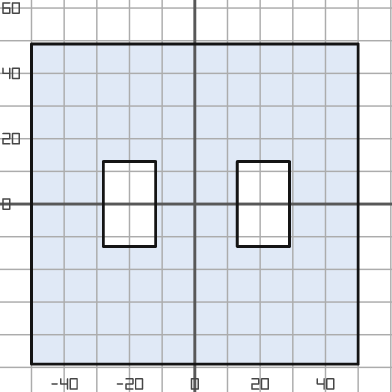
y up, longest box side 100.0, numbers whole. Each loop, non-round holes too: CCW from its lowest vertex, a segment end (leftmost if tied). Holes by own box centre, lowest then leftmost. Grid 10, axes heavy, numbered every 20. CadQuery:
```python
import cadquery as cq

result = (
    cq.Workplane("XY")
    .moveTo(-50.0, -49.0)
    .lineTo(50.0, -49.0)
    .lineTo(50.0, 49.0)
    .lineTo(-50.0, 49.0)
    .close()
    .moveTo(-28.0, -13.0)
    .lineTo(-12.0, -13.0)
    .lineTo(-12.0, 13.0)
    .lineTo(-28.0, 13.0)
    .close()
    .moveTo(13.0, -13.0)
    .lineTo(29.0, -13.0)
    .lineTo(29.0, 13.0)
    .lineTo(13.0, 13.0)
    .close()
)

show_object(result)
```